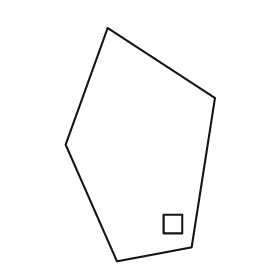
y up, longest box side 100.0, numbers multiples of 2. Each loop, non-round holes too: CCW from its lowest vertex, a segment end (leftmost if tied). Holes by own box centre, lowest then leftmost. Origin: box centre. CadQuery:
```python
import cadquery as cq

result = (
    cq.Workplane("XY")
    .moveTo(-10.0, -50.0)
    .lineTo(22.0, -44.0)
    .lineTo(32.0, 20.0)
    .lineTo(-14.0, 50.0)
    .lineTo(-32.0, 0.0)
    .close()
    .moveTo(10.0, -38.0)
    .lineTo(18.0, -38.0)
    .lineTo(18.0, -30.0)
    .lineTo(10.0, -30.0)
    .close()
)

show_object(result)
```